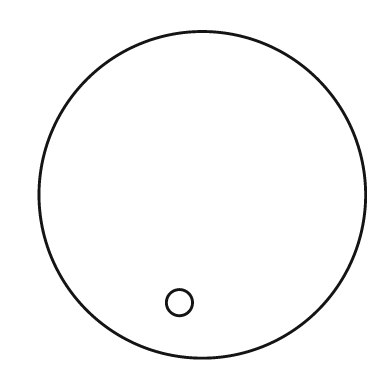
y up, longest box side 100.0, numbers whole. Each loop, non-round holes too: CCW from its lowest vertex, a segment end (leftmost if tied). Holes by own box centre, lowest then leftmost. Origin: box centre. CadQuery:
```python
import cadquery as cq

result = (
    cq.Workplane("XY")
    .moveTo(0.0, 0.0)
    .circle(50.0)
    .moveTo(-7.0, -33.0)
    .circle(4.0)
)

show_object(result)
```